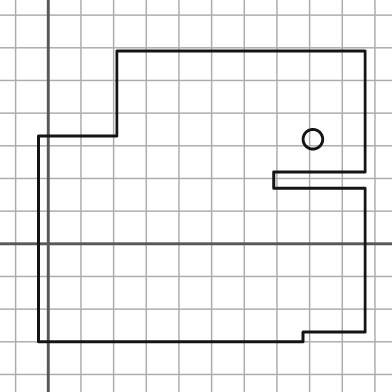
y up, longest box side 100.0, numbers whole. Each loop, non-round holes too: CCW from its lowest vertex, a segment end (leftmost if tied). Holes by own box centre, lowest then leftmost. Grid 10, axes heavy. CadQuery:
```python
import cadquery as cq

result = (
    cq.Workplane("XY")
    .moveTo(-3.0, -30.0)
    .lineTo(78.0, -30.0)
    .lineTo(78.0, -27.0)
    .lineTo(97.0, -27.0)
    .lineTo(97.0, 17.0)
    .lineTo(69.0, 17.0)
    .lineTo(69.0, 22.0)
    .lineTo(97.0, 22.0)
    .lineTo(97.0, 59.0)
    .lineTo(21.0, 59.0)
    .lineTo(21.0, 33.0)
    .lineTo(-3.0, 33.0)
    .close()
    .moveTo(81.0, 32.0)
    .circle(3.0)
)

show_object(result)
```